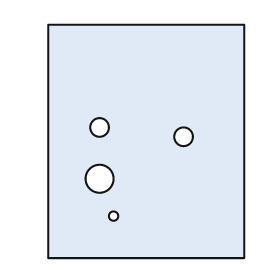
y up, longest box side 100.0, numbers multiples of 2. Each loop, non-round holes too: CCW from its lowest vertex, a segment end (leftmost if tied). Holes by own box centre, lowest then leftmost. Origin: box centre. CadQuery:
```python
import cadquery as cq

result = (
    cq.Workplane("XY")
    .moveTo(-42.0, -50.0)
    .lineTo(42.0, -50.0)
    .lineTo(42.0, 50.0)
    .lineTo(-42.0, 50.0)
    .close()
    .moveTo(-14.0, -32.0)
    .circle(2.0)
    .moveTo(-20.0, -16.0)
    .circle(6.0)
    .moveTo(16.0, 2.0)
    .circle(4.0)
    .moveTo(-20.0, 6.0)
    .circle(4.0)
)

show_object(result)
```